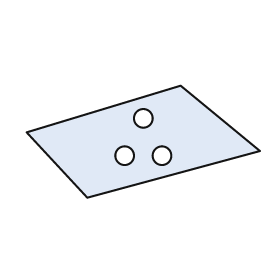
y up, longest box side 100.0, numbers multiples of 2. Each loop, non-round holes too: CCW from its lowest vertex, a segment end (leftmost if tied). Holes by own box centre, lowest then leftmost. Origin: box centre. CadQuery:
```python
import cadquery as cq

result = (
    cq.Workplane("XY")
    .moveTo(-24.0, -24.0)
    .lineTo(50.0, -4.0)
    .lineTo(16.0, 24.0)
    .lineTo(-50.0, 4.0)
    .close()
    .moveTo(-8.0, -6.0)
    .circle(4.0)
    .moveTo(8.0, -6.0)
    .circle(4.0)
    .moveTo(0.0, 10.0)
    .circle(4.0)
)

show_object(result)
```